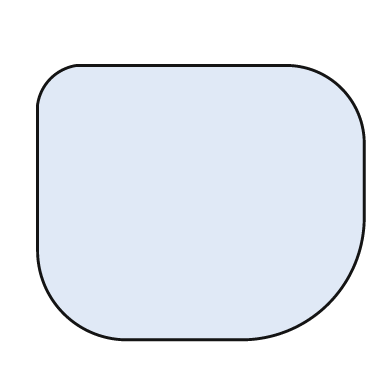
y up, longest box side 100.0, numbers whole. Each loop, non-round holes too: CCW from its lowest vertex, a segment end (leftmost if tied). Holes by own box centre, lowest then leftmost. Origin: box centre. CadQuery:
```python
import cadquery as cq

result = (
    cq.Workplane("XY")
    .moveTo(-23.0, -42.0)
    .lineTo(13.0, -42.0)
    .threePointArc((39.0, -31.0), (50.0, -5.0))
    .lineTo(50.0, 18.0)
    .threePointArc((43.0, 35.0), (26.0, 42.0))
    .lineTo(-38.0, 42.0)
    .threePointArc((-46.0, 38.0), (-50.0, 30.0))
    .lineTo(-50.0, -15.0)
    .threePointArc((-42.0, -34.0), (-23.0, -42.0))
    .close()
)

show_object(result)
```